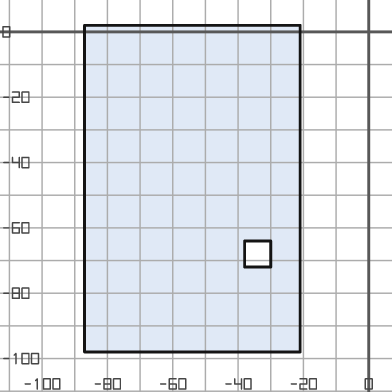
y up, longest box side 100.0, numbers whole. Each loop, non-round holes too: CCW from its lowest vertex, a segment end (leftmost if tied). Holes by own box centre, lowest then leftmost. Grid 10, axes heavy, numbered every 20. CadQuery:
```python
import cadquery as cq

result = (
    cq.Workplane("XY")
    .moveTo(-87.0, -98.0)
    .lineTo(-21.0, -98.0)
    .lineTo(-21.0, 2.0)
    .lineTo(-87.0, 2.0)
    .close()
    .moveTo(-38.0, -72.0)
    .lineTo(-30.0, -72.0)
    .lineTo(-30.0, -64.0)
    .lineTo(-38.0, -64.0)
    .close()
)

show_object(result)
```